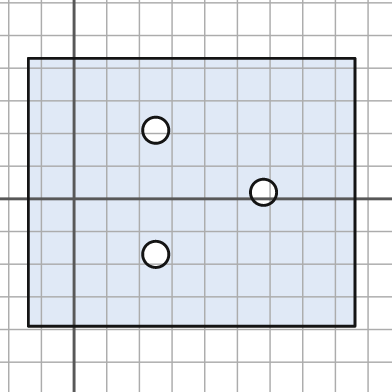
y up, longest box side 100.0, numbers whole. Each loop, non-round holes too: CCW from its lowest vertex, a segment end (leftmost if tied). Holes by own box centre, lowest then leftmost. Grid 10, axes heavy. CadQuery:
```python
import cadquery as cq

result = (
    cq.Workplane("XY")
    .moveTo(-14.0, -39.0)
    .lineTo(86.0, -39.0)
    .lineTo(86.0, 43.0)
    .lineTo(-14.0, 43.0)
    .close()
    .moveTo(25.0, -17.0)
    .circle(4.0)
    .moveTo(58.0, 2.0)
    .circle(4.0)
    .moveTo(25.0, 21.0)
    .circle(4.0)
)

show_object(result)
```